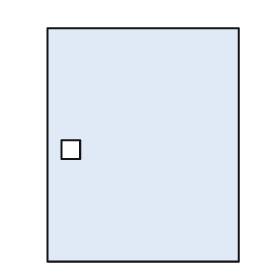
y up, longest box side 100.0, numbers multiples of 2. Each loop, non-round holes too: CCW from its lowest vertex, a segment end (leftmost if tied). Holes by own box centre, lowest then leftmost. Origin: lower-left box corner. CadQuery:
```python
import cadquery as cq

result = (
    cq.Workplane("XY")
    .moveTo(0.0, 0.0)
    .lineTo(82.0, 0.0)
    .lineTo(82.0, 100.0)
    .lineTo(0.0, 100.0)
    .close()
    .moveTo(6.0, 44.0)
    .lineTo(14.0, 44.0)
    .lineTo(14.0, 52.0)
    .lineTo(6.0, 52.0)
    .close()
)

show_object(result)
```